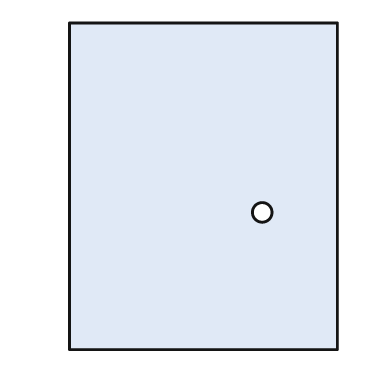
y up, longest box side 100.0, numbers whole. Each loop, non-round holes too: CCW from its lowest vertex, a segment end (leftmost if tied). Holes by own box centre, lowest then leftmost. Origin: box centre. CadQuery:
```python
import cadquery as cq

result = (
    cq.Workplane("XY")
    .moveTo(-41.0, -50.0)
    .lineTo(41.0, -50.0)
    .lineTo(41.0, 50.0)
    .lineTo(-41.0, 50.0)
    .close()
    .moveTo(18.0, -8.0)
    .circle(3.0)
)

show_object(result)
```